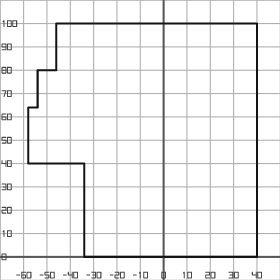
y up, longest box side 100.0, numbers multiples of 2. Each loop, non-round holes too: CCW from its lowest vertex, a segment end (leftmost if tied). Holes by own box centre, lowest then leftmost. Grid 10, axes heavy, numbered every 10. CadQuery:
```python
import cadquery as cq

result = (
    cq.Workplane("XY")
    .moveTo(-34.0, 0.0)
    .lineTo(40.0, 0.0)
    .lineTo(40.0, 100.0)
    .lineTo(-46.0, 100.0)
    .lineTo(-46.0, 80.0)
    .lineTo(-54.0, 80.0)
    .lineTo(-54.0, 64.0)
    .lineTo(-58.0, 64.0)
    .lineTo(-58.0, 40.0)
    .lineTo(-34.0, 40.0)
    .close()
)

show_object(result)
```